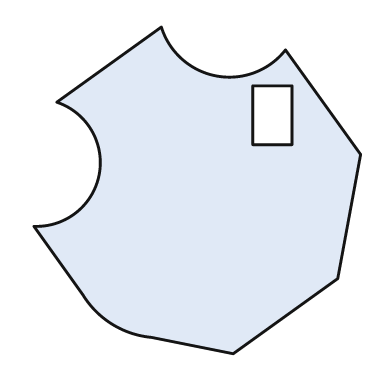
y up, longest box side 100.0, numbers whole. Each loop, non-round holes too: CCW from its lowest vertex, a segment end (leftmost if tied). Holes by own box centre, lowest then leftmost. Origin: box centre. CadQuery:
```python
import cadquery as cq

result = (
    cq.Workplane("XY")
    .moveTo(11.0, -50.0)
    .lineTo(43.0, -27.0)
    .lineTo(50.0, 11.0)
    .lineTo(27.0, 43.0)
    .threePointArc((6.0, 35.0), (-11.0, 50.0))
    .lineTo(-43.0, 27.0)
    .threePointArc((-30.0, 5.0), (-50.0, -11.0))
    .lineTo(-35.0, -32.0)
    .threePointArc((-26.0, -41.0), (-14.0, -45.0))
    .close()
    .moveTo(17.0, 14.0)
    .lineTo(29.0, 14.0)
    .lineTo(29.0, 32.0)
    .lineTo(17.0, 32.0)
    .close()
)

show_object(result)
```